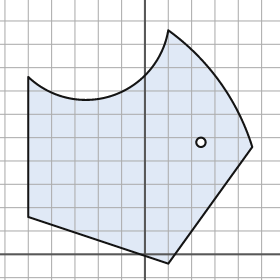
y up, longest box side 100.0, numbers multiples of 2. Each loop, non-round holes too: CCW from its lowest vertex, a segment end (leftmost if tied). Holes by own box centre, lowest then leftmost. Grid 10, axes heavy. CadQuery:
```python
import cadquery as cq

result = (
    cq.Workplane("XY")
    .moveTo(10.0, -4.0)
    .lineTo(46.0, 46.0)
    .threePointArc((32.0, 74.0), (10.0, 96.0))
    .threePointArc((-14.0, 68.0), (-50.0, 76.0))
    .lineTo(-50.0, 16.0)
    .close()
    .moveTo(24.0, 48.0)
    .circle(2.0)
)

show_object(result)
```